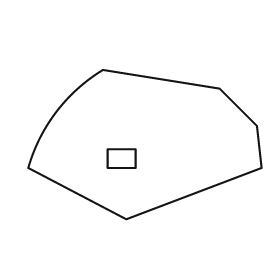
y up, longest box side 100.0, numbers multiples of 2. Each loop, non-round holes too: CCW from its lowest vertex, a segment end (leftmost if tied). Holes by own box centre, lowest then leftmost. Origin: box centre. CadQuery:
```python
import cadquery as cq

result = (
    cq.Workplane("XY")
    .moveTo(-8.0, -32.0)
    .lineTo(50.0, -10.0)
    .lineTo(48.0, 8.0)
    .lineTo(32.0, 24.0)
    .lineTo(-18.0, 32.0)
    .threePointArc((-38.0, 14.0), (-50.0, -10.0))
    .close()
    .moveTo(-16.0, -10.0)
    .lineTo(-4.0, -10.0)
    .lineTo(-4.0, -2.0)
    .lineTo(-16.0, -2.0)
    .close()
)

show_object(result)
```